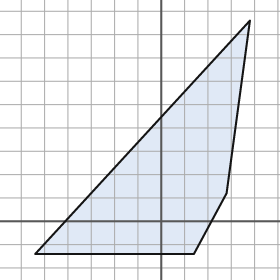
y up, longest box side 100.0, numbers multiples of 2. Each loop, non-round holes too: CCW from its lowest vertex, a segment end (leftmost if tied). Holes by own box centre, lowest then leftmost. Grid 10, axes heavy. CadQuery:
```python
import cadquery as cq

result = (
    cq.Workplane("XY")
    .moveTo(-54.0, -14.0)
    .lineTo(14.0, -14.0)
    .lineTo(28.0, 12.0)
    .lineTo(38.0, 86.0)
    .close()
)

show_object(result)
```